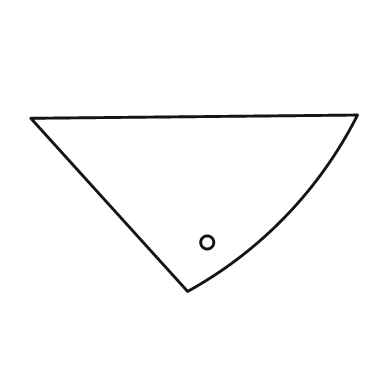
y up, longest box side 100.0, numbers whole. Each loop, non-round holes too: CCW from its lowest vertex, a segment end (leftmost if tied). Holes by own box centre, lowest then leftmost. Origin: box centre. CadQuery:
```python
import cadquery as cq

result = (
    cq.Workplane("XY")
    .moveTo(-2.0, -27.0)
    .threePointArc((28.0, -4.0), (50.0, 27.0))
    .lineTo(-50.0, 26.0)
    .close()
    .moveTo(4.0, -12.0)
    .circle(2.0)
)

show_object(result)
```